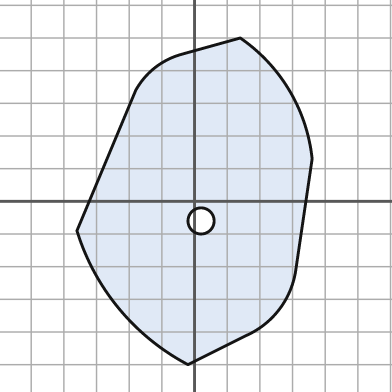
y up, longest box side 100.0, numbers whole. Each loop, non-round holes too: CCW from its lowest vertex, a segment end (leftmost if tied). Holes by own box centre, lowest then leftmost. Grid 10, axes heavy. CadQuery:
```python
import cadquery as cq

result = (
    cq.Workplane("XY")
    .moveTo(-2.0, -50.0)
    .lineTo(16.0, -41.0)
    .threePointArc((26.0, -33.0), (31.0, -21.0))
    .lineTo(36.0, 13.0)
    .threePointArc((29.0, 34.0), (14.0, 50.0))
    .lineTo(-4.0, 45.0)
    .threePointArc((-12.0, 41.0), (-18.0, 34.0))
    .lineTo(-36.0, -9.0)
    .threePointArc((-23.0, -33.0), (-2.0, -50.0))
    .close()
    .moveTo(2.0, -6.0)
    .circle(4.0)
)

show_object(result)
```